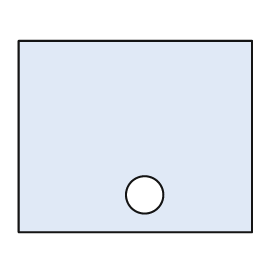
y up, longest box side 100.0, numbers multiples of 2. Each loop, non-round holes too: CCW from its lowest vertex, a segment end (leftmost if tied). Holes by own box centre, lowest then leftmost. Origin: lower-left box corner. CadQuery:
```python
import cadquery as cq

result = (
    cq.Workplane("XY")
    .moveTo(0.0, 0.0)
    .lineTo(100.0, 0.0)
    .lineTo(100.0, 82.0)
    .lineTo(0.0, 82.0)
    .close()
    .moveTo(54.0, 16.0)
    .circle(8.0)
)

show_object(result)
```